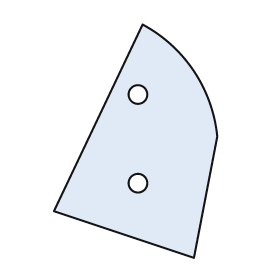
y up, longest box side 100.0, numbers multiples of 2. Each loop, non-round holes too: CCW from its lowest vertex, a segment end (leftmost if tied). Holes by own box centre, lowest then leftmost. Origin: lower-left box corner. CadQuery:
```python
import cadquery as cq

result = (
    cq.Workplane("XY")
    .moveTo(60.0, 0.0)
    .lineTo(70.0, 52.0)
    .threePointArc((60.0, 80.0), (38.0, 100.0))
    .lineTo(0.0, 20.0)
    .close()
    .moveTo(36.0, 32.0)
    .circle(4.0)
    .moveTo(36.0, 70.0)
    .circle(4.0)
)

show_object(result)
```